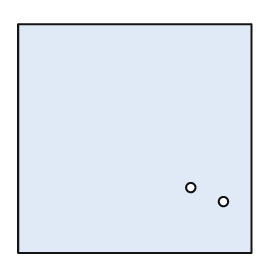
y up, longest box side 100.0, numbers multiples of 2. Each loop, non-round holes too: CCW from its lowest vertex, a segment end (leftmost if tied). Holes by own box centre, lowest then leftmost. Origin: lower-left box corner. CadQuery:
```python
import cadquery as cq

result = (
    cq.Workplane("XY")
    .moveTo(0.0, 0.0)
    .lineTo(100.0, 0.0)
    .lineTo(100.0, 98.0)
    .lineTo(0.0, 98.0)
    .close()
    .moveTo(88.0, 22.0)
    .circle(2.0)
    .moveTo(74.0, 28.0)
    .circle(2.0)
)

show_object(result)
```